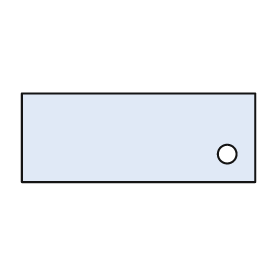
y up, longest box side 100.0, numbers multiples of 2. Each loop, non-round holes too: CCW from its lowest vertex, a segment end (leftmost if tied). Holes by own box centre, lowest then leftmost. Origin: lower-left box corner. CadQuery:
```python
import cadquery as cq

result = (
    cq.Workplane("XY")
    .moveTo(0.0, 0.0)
    .lineTo(100.0, 0.0)
    .lineTo(100.0, 38.0)
    .lineTo(0.0, 38.0)
    .close()
    .moveTo(88.0, 12.0)
    .circle(4.0)
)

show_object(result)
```